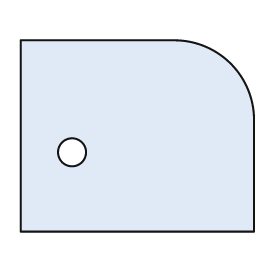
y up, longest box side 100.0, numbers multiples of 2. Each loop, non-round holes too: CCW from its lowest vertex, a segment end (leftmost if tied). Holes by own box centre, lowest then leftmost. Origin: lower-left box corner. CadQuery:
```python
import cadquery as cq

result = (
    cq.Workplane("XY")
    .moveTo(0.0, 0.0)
    .lineTo(100.0, 0.0)
    .lineTo(100.0, 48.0)
    .threePointArc((90.0, 72.0), (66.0, 82.0))
    .lineTo(0.0, 82.0)
    .close()
    .moveTo(22.0, 34.0)
    .circle(6.0)
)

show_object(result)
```